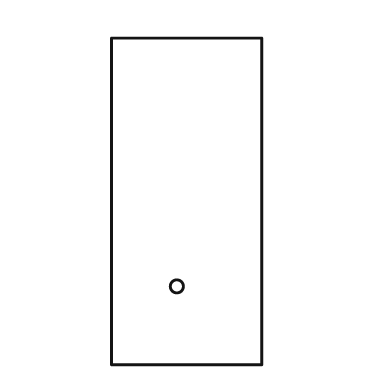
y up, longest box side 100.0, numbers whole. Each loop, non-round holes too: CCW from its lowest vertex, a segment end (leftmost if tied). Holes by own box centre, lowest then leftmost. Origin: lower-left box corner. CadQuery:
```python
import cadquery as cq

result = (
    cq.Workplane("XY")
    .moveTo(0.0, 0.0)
    .lineTo(46.0, 0.0)
    .lineTo(46.0, 100.0)
    .lineTo(0.0, 100.0)
    .close()
    .moveTo(20.0, 24.0)
    .circle(2.0)
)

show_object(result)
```